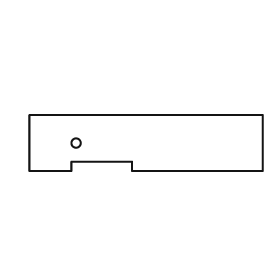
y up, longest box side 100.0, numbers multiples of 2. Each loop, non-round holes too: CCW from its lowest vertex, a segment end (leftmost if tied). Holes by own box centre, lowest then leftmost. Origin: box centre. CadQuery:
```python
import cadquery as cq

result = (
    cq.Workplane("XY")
    .moveTo(-50.0, -12.0)
    .lineTo(-32.0, -12.0)
    .lineTo(-32.0, -8.0)
    .lineTo(-6.0, -8.0)
    .lineTo(-6.0, -12.0)
    .lineTo(50.0, -12.0)
    .lineTo(50.0, 12.0)
    .lineTo(-50.0, 12.0)
    .close()
    .moveTo(-30.0, 0.0)
    .circle(2.0)
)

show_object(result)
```